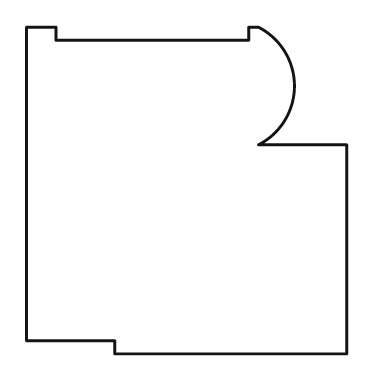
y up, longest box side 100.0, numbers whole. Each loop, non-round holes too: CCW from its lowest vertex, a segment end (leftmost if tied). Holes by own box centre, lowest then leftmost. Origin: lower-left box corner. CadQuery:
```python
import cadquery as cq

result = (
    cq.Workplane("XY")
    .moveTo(27.0, 0.0)
    .lineTo(98.0, 0.0)
    .lineTo(98.0, 64.0)
    .lineTo(71.0, 64.0)
    .threePointArc((82.0, 82.0), (71.0, 100.0))
    .lineTo(68.0, 100.0)
    .lineTo(68.0, 96.0)
    .lineTo(9.0, 96.0)
    .lineTo(9.0, 100.0)
    .lineTo(0.0, 100.0)
    .lineTo(0.0, 4.0)
    .lineTo(27.0, 4.0)
    .close()
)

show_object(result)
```